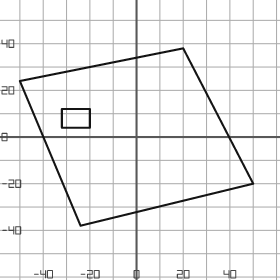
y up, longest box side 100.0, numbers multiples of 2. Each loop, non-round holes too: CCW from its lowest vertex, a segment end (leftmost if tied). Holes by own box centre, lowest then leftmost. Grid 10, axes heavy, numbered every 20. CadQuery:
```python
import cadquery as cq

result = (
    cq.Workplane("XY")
    .moveTo(-24.0, -38.0)
    .lineTo(50.0, -20.0)
    .lineTo(20.0, 38.0)
    .lineTo(-50.0, 24.0)
    .close()
    .moveTo(-32.0, 4.0)
    .lineTo(-20.0, 4.0)
    .lineTo(-20.0, 12.0)
    .lineTo(-32.0, 12.0)
    .close()
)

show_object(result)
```